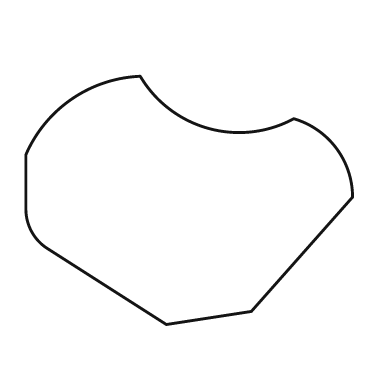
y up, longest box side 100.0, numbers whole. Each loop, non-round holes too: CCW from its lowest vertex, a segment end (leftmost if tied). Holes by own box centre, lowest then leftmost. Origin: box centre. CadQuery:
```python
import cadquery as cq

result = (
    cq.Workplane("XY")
    .moveTo(-7.0, -38.0)
    .lineTo(19.0, -34.0)
    .lineTo(50.0, 1.0)
    .threePointArc((45.0, 16.0), (32.0, 25.0))
    .threePointArc((6.0, 22.0), (-15.0, 38.0))
    .threePointArc((-36.0, 31.0), (-50.0, 14.0))
    .lineTo(-50.0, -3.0)
    .threePointArc((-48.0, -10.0), (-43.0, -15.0))
    .close()
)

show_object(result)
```